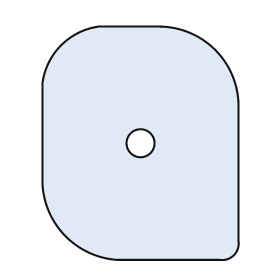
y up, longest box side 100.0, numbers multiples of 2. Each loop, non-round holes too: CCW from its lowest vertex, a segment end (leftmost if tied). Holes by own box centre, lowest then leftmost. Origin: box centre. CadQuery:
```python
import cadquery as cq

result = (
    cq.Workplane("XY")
    .moveTo(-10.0, -50.0)
    .lineTo(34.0, -50.0)
    .threePointArc((40.0, -48.0), (42.0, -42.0))
    .lineTo(42.0, 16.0)
    .threePointArc((32.0, 40.0), (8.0, 50.0))
    .lineTo(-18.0, 50.0)
    .threePointArc((-34.0, 42.0), (-42.0, 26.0))
    .lineTo(-42.0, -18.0)
    .threePointArc((-32.0, -40.0), (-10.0, -50.0))
    .close()
    .moveTo(0.0, 0.0)
    .circle(6.0)
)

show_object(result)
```